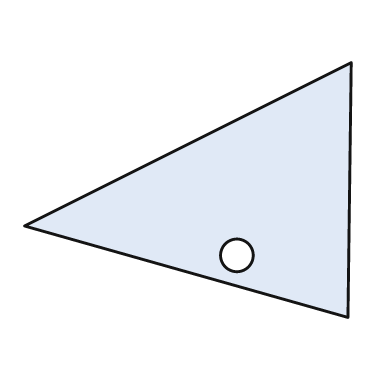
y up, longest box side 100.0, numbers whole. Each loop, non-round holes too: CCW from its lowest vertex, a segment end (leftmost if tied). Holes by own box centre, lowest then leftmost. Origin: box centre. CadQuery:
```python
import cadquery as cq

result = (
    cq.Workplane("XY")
    .moveTo(49.0, -39.0)
    .lineTo(50.0, 39.0)
    .lineTo(-50.0, -11.0)
    .close()
    .moveTo(15.0, -20.0)
    .circle(5.0)
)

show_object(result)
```